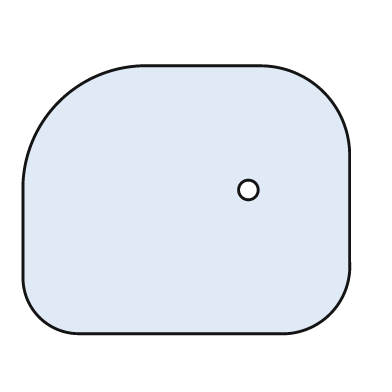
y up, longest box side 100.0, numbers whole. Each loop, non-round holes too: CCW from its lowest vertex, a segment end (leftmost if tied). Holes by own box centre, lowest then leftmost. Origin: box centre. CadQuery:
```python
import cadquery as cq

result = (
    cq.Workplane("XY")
    .moveTo(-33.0, -41.0)
    .lineTo(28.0, -41.0)
    .threePointArc((44.0, -35.0), (50.0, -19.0))
    .lineTo(50.0, 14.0)
    .threePointArc((42.0, 33.0), (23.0, 41.0))
    .lineTo(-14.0, 41.0)
    .threePointArc((-39.0, 30.0), (-50.0, 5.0))
    .lineTo(-50.0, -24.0)
    .threePointArc((-45.0, -36.0), (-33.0, -41.0))
    .close()
    .moveTo(19.0, 3.0)
    .circle(3.0)
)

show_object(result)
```